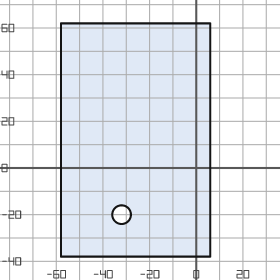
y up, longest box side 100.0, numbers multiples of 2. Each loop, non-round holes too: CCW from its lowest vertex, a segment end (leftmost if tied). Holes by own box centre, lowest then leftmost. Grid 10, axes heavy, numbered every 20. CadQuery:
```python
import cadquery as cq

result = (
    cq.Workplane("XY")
    .moveTo(-58.0, -38.0)
    .lineTo(6.0, -38.0)
    .lineTo(6.0, 62.0)
    .lineTo(-58.0, 62.0)
    .close()
    .moveTo(-32.0, -20.0)
    .circle(4.0)
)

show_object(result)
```